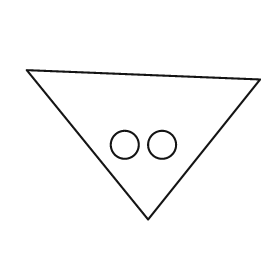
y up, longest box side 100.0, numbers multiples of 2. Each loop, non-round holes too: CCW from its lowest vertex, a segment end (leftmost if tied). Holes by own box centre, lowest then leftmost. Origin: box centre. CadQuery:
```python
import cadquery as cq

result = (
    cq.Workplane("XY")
    .moveTo(2.0, -32.0)
    .lineTo(50.0, 28.0)
    .lineTo(-50.0, 32.0)
    .close()
    .moveTo(-8.0, 0.0)
    .circle(6.0)
    .moveTo(8.0, 0.0)
    .circle(6.0)
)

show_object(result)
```